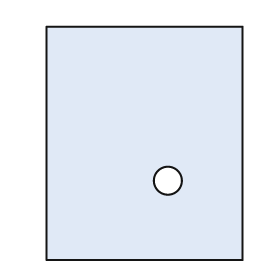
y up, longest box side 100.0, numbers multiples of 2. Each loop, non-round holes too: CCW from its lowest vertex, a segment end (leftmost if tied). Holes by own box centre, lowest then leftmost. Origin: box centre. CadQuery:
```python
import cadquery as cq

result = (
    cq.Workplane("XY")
    .moveTo(-42.0, -50.0)
    .lineTo(42.0, -50.0)
    .lineTo(42.0, 50.0)
    .lineTo(-42.0, 50.0)
    .close()
    .moveTo(10.0, -16.0)
    .circle(6.0)
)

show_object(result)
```